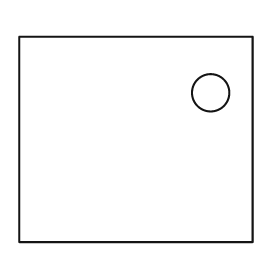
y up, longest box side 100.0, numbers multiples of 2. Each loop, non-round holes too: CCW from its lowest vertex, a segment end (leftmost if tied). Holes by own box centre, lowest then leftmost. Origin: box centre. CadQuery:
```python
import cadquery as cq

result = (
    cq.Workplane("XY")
    .moveTo(-50.0, -44.0)
    .lineTo(50.0, -44.0)
    .lineTo(50.0, 44.0)
    .lineTo(-50.0, 44.0)
    .close()
    .moveTo(32.0, 20.0)
    .circle(8.0)
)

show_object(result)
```